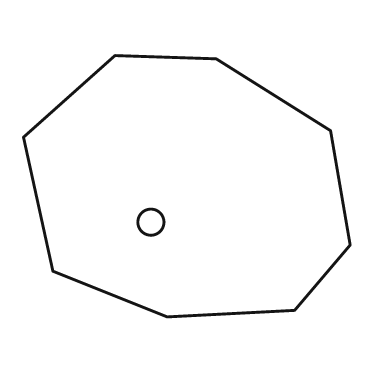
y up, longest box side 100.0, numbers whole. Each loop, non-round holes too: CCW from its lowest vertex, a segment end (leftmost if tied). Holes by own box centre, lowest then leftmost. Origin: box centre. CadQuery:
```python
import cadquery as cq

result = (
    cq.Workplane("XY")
    .moveTo(-6.0, -40.0)
    .lineTo(33.0, -38.0)
    .lineTo(50.0, -18.0)
    .lineTo(44.0, 17.0)
    .lineTo(9.0, 39.0)
    .lineTo(-22.0, 40.0)
    .lineTo(-50.0, 15.0)
    .lineTo(-41.0, -26.0)
    .close()
    .moveTo(-11.0, -11.0)
    .circle(4.0)
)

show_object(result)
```